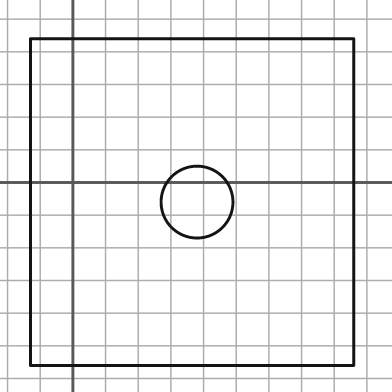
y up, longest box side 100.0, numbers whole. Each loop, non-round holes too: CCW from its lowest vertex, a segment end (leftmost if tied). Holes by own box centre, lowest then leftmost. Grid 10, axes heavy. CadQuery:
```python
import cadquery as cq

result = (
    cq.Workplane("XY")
    .moveTo(-13.0, -56.0)
    .lineTo(86.0, -56.0)
    .lineTo(86.0, 44.0)
    .lineTo(-13.0, 44.0)
    .close()
    .moveTo(38.0, -6.0)
    .circle(11.0)
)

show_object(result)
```